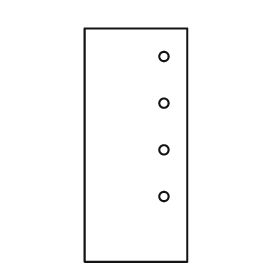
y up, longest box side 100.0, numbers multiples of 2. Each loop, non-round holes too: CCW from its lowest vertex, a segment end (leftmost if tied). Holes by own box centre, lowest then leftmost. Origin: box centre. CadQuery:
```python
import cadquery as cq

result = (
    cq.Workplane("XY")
    .moveTo(-22.0, -50.0)
    .lineTo(22.0, -50.0)
    .lineTo(22.0, 50.0)
    .lineTo(-22.0, 50.0)
    .close()
    .moveTo(12.0, -22.0)
    .circle(2.0)
    .moveTo(12.0, -2.0)
    .circle(2.0)
    .moveTo(12.0, 18.0)
    .circle(2.0)
    .moveTo(12.0, 38.0)
    .circle(2.0)
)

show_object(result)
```